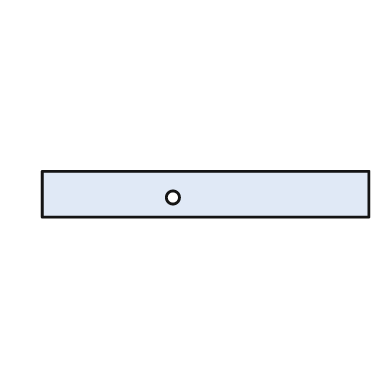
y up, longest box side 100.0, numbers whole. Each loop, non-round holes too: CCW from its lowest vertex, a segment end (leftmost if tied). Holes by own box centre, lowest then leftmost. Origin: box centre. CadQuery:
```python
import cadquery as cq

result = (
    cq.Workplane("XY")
    .moveTo(-50.0, -7.0)
    .lineTo(50.0, -7.0)
    .lineTo(50.0, 7.0)
    .lineTo(-50.0, 7.0)
    .close()
    .moveTo(-10.0, -1.0)
    .circle(2.0)
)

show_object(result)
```